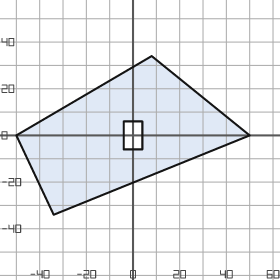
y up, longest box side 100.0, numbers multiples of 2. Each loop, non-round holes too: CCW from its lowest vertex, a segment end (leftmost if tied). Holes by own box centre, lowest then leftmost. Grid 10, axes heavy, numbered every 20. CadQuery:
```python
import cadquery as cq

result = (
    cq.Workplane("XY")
    .moveTo(-34.0, -34.0)
    .lineTo(50.0, 0.0)
    .lineTo(8.0, 34.0)
    .lineTo(-50.0, 0.0)
    .close()
    .moveTo(-4.0, -6.0)
    .lineTo(4.0, -6.0)
    .lineTo(4.0, 6.0)
    .lineTo(-4.0, 6.0)
    .close()
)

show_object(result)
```